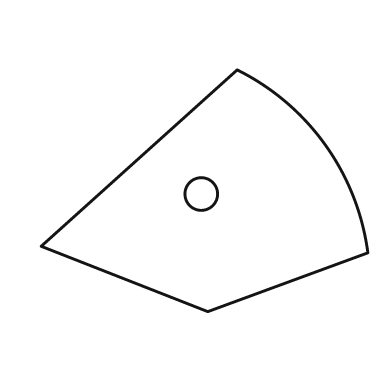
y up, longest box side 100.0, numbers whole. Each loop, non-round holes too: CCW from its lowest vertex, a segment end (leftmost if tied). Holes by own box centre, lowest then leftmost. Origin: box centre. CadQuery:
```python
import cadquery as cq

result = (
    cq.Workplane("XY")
    .moveTo(1.0, -37.0)
    .lineTo(50.0, -19.0)
    .threePointArc((37.0, 14.0), (10.0, 37.0))
    .lineTo(-50.0, -17.0)
    .close()
    .moveTo(-1.0, -1.0)
    .circle(5.0)
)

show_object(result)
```